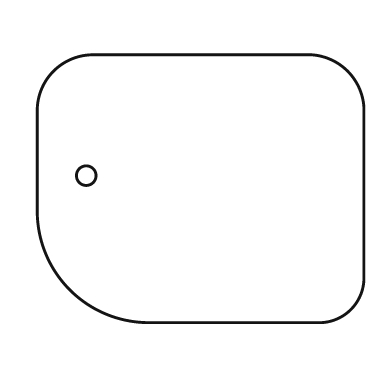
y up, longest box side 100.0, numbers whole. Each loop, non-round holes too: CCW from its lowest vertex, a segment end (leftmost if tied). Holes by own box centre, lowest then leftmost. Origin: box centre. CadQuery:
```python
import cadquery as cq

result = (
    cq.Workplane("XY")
    .moveTo(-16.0, -41.0)
    .lineTo(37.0, -41.0)
    .threePointArc((46.0, -37.0), (50.0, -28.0))
    .lineTo(50.0, 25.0)
    .threePointArc((45.0, 36.0), (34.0, 41.0))
    .lineTo(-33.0, 41.0)
    .threePointArc((-45.0, 36.0), (-50.0, 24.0))
    .lineTo(-50.0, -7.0)
    .threePointArc((-40.0, -31.0), (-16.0, -41.0))
    .close()
    .moveTo(-35.0, 4.0)
    .circle(3.0)
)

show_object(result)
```